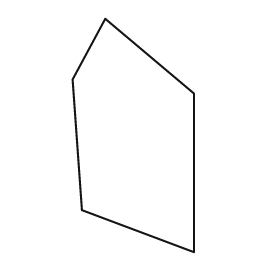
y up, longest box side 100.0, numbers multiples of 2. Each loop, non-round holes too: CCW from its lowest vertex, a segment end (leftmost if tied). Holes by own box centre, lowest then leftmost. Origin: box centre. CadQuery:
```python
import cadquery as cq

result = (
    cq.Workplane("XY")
    .moveTo(26.0, -50.0)
    .lineTo(26.0, 18.0)
    .lineTo(-12.0, 50.0)
    .lineTo(-26.0, 24.0)
    .lineTo(-22.0, -32.0)
    .close()
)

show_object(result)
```